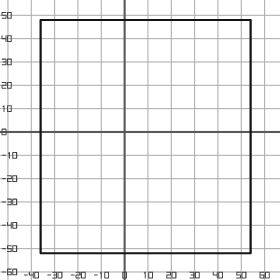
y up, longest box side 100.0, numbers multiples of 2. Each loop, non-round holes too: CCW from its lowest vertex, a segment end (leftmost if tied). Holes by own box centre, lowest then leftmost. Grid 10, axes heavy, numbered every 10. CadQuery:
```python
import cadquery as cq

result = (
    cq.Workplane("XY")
    .moveTo(-36.0, -52.0)
    .lineTo(54.0, -52.0)
    .lineTo(54.0, 48.0)
    .lineTo(-36.0, 48.0)
    .close()
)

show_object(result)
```